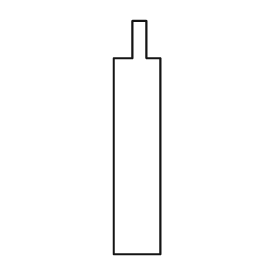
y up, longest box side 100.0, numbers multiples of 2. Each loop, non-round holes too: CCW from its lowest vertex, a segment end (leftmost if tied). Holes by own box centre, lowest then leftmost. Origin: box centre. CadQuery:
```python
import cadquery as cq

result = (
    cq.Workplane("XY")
    .moveTo(-10.0, -50.0)
    .lineTo(10.0, -50.0)
    .lineTo(10.0, 34.0)
    .lineTo(4.0, 34.0)
    .lineTo(4.0, 50.0)
    .lineTo(-2.0, 50.0)
    .lineTo(-2.0, 34.0)
    .lineTo(-10.0, 34.0)
    .close()
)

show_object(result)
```